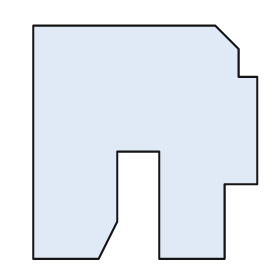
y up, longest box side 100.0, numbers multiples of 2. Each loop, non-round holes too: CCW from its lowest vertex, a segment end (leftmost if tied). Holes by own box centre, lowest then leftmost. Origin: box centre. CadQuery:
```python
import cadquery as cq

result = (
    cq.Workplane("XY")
    .moveTo(-48.0, -50.0)
    .lineTo(-20.0, -50.0)
    .lineTo(-12.0, -34.0)
    .lineTo(-12.0, -4.0)
    .lineTo(6.0, -4.0)
    .lineTo(6.0, -50.0)
    .lineTo(34.0, -50.0)
    .lineTo(34.0, -18.0)
    .lineTo(48.0, -18.0)
    .lineTo(48.0, 28.0)
    .lineTo(40.0, 28.0)
    .lineTo(40.0, 40.0)
    .lineTo(30.0, 50.0)
    .lineTo(-48.0, 50.0)
    .close()
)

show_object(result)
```